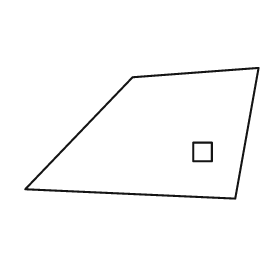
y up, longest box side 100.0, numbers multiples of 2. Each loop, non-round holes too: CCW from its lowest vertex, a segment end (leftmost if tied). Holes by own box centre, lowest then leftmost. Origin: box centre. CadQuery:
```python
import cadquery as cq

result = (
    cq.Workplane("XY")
    .moveTo(40.0, -28.0)
    .lineTo(50.0, 28.0)
    .lineTo(-4.0, 24.0)
    .lineTo(-50.0, -24.0)
    .close()
    .moveTo(22.0, -12.0)
    .lineTo(30.0, -12.0)
    .lineTo(30.0, -4.0)
    .lineTo(22.0, -4.0)
    .close()
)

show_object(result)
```